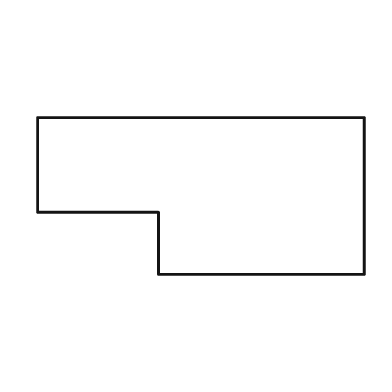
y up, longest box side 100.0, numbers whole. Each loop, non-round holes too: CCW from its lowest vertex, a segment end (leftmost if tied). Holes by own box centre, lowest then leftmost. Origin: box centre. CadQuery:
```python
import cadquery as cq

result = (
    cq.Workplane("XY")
    .moveTo(-13.0, -24.0)
    .lineTo(50.0, -24.0)
    .lineTo(50.0, 24.0)
    .lineTo(-50.0, 24.0)
    .lineTo(-50.0, -5.0)
    .lineTo(-13.0, -5.0)
    .close()
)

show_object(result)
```